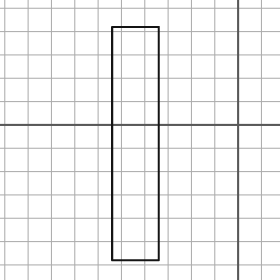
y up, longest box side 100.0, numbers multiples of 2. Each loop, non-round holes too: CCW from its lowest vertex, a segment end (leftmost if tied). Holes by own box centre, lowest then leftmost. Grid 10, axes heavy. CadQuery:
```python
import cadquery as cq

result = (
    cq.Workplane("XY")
    .moveTo(-54.0, -58.0)
    .lineTo(-34.0, -58.0)
    .lineTo(-34.0, 42.0)
    .lineTo(-54.0, 42.0)
    .close()
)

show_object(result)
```